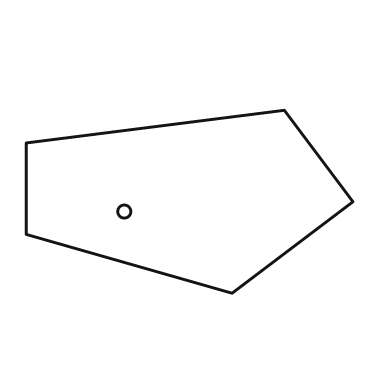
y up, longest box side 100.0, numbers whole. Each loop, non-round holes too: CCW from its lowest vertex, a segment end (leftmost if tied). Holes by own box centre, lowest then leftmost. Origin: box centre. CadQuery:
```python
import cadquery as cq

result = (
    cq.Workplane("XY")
    .moveTo(13.0, -28.0)
    .lineTo(50.0, 0.0)
    .lineTo(29.0, 28.0)
    .lineTo(-50.0, 18.0)
    .lineTo(-50.0, -10.0)
    .close()
    .moveTo(-20.0, -3.0)
    .circle(2.0)
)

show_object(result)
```